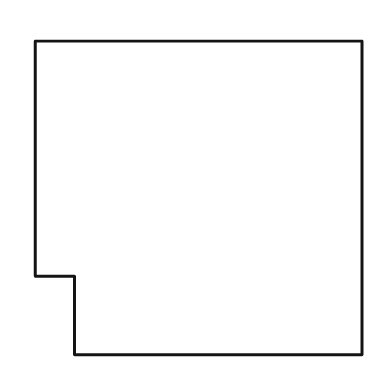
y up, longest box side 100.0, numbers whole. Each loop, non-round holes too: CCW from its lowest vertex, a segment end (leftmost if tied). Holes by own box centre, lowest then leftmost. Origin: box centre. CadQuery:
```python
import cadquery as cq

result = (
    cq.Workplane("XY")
    .moveTo(-38.0, -48.0)
    .lineTo(50.0, -48.0)
    .lineTo(50.0, 48.0)
    .lineTo(-50.0, 48.0)
    .lineTo(-50.0, -24.0)
    .lineTo(-38.0, -24.0)
    .close()
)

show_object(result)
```